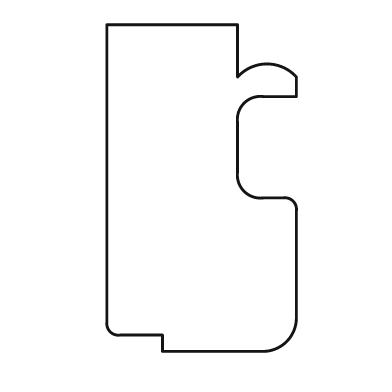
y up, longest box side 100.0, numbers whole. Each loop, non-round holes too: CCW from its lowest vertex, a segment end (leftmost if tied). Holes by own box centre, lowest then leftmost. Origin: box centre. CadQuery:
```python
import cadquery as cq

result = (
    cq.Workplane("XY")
    .moveTo(-12.0, -50.0)
    .lineTo(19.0, -50.0)
    .threePointArc((26.0, -47.0), (29.0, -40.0))
    .lineTo(29.0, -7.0)
    .threePointArc((28.0, -4.0), (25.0, -3.0))
    .lineTo(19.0, -3.0)
    .threePointArc((13.0, -1.0), (11.0, 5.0))
    .lineTo(11.0, 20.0)
    .threePointArc((13.0, 26.0), (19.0, 28.0))
    .lineTo(29.0, 28.0)
    .lineTo(29.0, 34.0)
    .threePointArc((20.0, 38.0), (11.0, 34.0))
    .lineTo(11.0, 50.0)
    .lineTo(-29.0, 50.0)
    .lineTo(-29.0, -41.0)
    .threePointArc((-28.0, -44.0), (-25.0, -45.0))
    .lineTo(-12.0, -45.0)
    .close()
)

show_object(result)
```